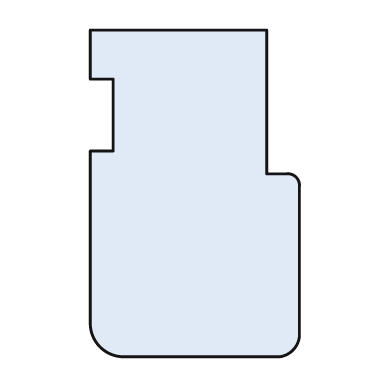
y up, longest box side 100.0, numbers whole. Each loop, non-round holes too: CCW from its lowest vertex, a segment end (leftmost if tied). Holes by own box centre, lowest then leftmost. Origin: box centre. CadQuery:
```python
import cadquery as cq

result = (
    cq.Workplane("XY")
    .moveTo(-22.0, -50.0)
    .lineTo(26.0, -50.0)
    .threePointArc((30.0, -48.0), (32.0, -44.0))
    .lineTo(32.0, 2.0)
    .threePointArc((31.0, 5.0), (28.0, 6.0))
    .lineTo(22.0, 6.0)
    .lineTo(22.0, 50.0)
    .lineTo(-32.0, 50.0)
    .lineTo(-32.0, 35.0)
    .lineTo(-25.0, 35.0)
    .lineTo(-25.0, 13.0)
    .lineTo(-32.0, 13.0)
    .lineTo(-32.0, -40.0)
    .threePointArc((-29.0, -47.0), (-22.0, -50.0))
    .close()
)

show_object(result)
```